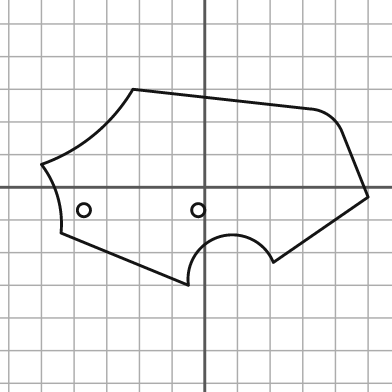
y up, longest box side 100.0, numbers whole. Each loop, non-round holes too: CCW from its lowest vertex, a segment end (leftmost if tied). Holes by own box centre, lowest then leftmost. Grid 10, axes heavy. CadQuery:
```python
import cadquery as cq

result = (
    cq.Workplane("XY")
    .moveTo(-5.0, -30.0)
    .threePointArc((5.0, -15.0), (21.0, -23.0))
    .lineTo(50.0, -3.0)
    .lineTo(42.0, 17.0)
    .threePointArc((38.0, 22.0), (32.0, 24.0))
    .lineTo(-22.0, 30.0)
    .threePointArc((-34.0, 16.0), (-50.0, 7.0))
    .threePointArc((-45.0, -3.0), (-44.0, -14.0))
    .close()
    .moveTo(-37.0, -7.0)
    .circle(2.0)
    .moveTo(-2.0, -7.0)
    .circle(2.0)
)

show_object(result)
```